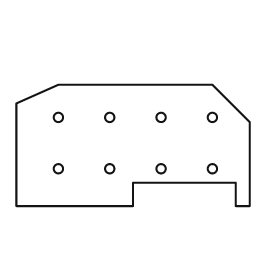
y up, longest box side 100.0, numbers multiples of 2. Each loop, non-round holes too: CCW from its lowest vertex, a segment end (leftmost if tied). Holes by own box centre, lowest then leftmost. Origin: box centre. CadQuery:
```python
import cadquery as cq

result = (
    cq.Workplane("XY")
    .moveTo(-50.0, -26.0)
    .lineTo(0.0, -26.0)
    .lineTo(0.0, -16.0)
    .lineTo(44.0, -16.0)
    .lineTo(44.0, -26.0)
    .lineTo(50.0, -26.0)
    .lineTo(50.0, 10.0)
    .lineTo(34.0, 26.0)
    .lineTo(-32.0, 26.0)
    .lineTo(-50.0, 18.0)
    .close()
    .moveTo(-32.0, -10.0)
    .circle(2.0)
    .moveTo(-10.0, -10.0)
    .circle(2.0)
    .moveTo(12.0, -10.0)
    .circle(2.0)
    .moveTo(34.0, -10.0)
    .circle(2.0)
    .moveTo(-32.0, 12.0)
    .circle(2.0)
    .moveTo(-10.0, 12.0)
    .circle(2.0)
    .moveTo(12.0, 12.0)
    .circle(2.0)
    .moveTo(34.0, 12.0)
    .circle(2.0)
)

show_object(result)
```